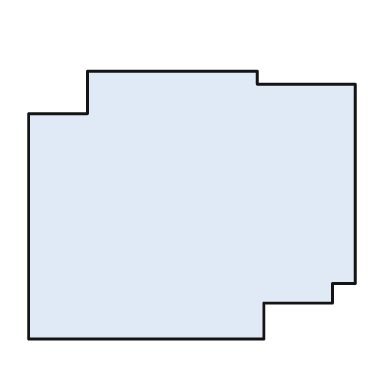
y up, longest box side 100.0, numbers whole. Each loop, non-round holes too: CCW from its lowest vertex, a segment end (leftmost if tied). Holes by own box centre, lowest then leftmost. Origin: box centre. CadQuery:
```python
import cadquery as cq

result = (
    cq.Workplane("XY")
    .moveTo(-50.0, -41.0)
    .lineTo(22.0, -41.0)
    .lineTo(22.0, -30.0)
    .lineTo(43.0, -30.0)
    .lineTo(43.0, -24.0)
    .lineTo(50.0, -24.0)
    .lineTo(50.0, 37.0)
    .lineTo(20.0, 37.0)
    .lineTo(20.0, 41.0)
    .lineTo(-32.0, 41.0)
    .lineTo(-32.0, 28.0)
    .lineTo(-50.0, 28.0)
    .close()
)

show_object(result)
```